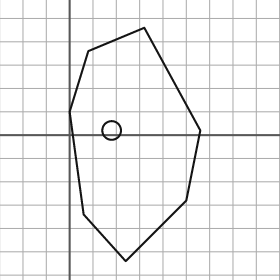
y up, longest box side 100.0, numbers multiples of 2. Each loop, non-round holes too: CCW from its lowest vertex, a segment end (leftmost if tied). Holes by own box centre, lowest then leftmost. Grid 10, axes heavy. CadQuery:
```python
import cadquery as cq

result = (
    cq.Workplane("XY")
    .moveTo(24.0, -54.0)
    .lineTo(50.0, -28.0)
    .lineTo(56.0, 2.0)
    .lineTo(32.0, 46.0)
    .lineTo(8.0, 36.0)
    .lineTo(0.0, 10.0)
    .lineTo(6.0, -34.0)
    .close()
    .moveTo(18.0, 2.0)
    .circle(4.0)
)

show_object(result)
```